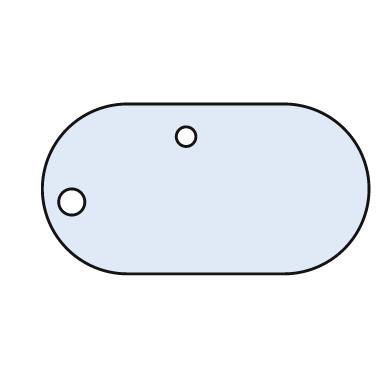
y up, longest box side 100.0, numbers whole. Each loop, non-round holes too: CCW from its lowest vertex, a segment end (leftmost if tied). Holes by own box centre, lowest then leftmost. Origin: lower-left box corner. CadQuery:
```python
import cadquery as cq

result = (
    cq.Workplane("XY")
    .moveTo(26.0, 0.0)
    .lineTo(74.0, 0.0)
    .threePointArc((100.0, 26.0), (74.0, 52.0))
    .lineTo(26.0, 52.0)
    .threePointArc((0.0, 26.0), (26.0, 0.0))
    .close()
    .moveTo(9.0, 22.0)
    .circle(4.0)
    .moveTo(44.0, 42.0)
    .circle(3.0)
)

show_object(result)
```